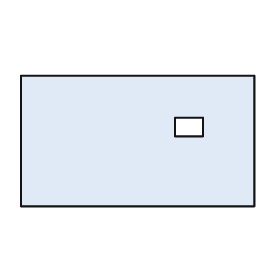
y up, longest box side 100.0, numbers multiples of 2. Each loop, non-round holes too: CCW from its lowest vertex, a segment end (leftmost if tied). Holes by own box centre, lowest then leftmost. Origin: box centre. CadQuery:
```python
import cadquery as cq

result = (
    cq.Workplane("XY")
    .moveTo(-50.0, -28.0)
    .lineTo(50.0, -28.0)
    .lineTo(50.0, 28.0)
    .lineTo(-50.0, 28.0)
    .close()
    .moveTo(16.0, 2.0)
    .lineTo(28.0, 2.0)
    .lineTo(28.0, 10.0)
    .lineTo(16.0, 10.0)
    .close()
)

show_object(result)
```